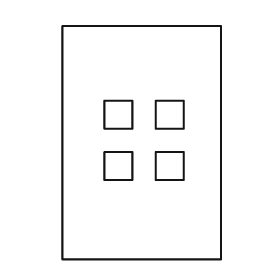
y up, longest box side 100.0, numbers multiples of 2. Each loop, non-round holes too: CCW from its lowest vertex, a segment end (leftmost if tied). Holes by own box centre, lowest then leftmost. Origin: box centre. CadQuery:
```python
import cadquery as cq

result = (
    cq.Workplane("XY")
    .moveTo(-34.0, -50.0)
    .lineTo(34.0, -50.0)
    .lineTo(34.0, 50.0)
    .lineTo(-34.0, 50.0)
    .close()
    .moveTo(-16.0, -16.0)
    .lineTo(-4.0, -16.0)
    .lineTo(-4.0, -4.0)
    .lineTo(-16.0, -4.0)
    .close()
    .moveTo(6.0, -16.0)
    .lineTo(18.0, -16.0)
    .lineTo(18.0, -4.0)
    .lineTo(6.0, -4.0)
    .close()
    .moveTo(-16.0, 6.0)
    .lineTo(-4.0, 6.0)
    .lineTo(-4.0, 18.0)
    .lineTo(-16.0, 18.0)
    .close()
    .moveTo(6.0, 6.0)
    .lineTo(18.0, 6.0)
    .lineTo(18.0, 18.0)
    .lineTo(6.0, 18.0)
    .close()
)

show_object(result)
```